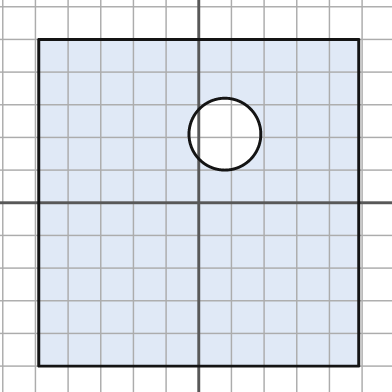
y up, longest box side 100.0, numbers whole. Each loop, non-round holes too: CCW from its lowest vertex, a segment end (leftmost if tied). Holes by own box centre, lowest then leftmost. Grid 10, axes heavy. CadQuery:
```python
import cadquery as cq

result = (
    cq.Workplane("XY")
    .moveTo(-49.0, -50.0)
    .lineTo(49.0, -50.0)
    .lineTo(49.0, 50.0)
    .lineTo(-49.0, 50.0)
    .close()
    .moveTo(8.0, 21.0)
    .circle(11.0)
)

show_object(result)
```